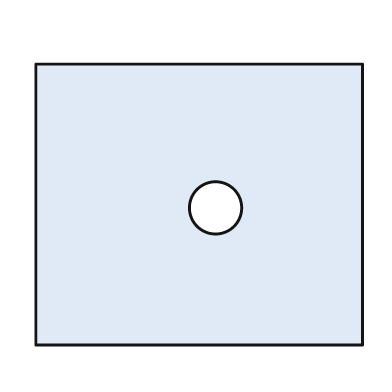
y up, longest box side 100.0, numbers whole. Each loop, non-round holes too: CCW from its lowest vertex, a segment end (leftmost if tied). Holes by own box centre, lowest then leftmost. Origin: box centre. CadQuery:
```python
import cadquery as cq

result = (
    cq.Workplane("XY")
    .moveTo(-50.0, -43.0)
    .lineTo(50.0, -43.0)
    .lineTo(50.0, 43.0)
    .lineTo(-50.0, 43.0)
    .close()
    .moveTo(5.0, -1.0)
    .circle(8.0)
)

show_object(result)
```